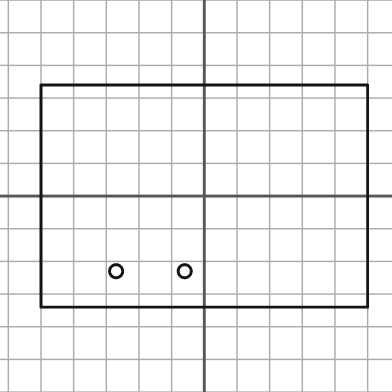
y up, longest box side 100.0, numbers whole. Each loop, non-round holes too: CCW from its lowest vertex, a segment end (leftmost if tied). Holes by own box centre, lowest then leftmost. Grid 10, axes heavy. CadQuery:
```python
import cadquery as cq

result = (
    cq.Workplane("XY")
    .moveTo(-50.0, -34.0)
    .lineTo(50.0, -34.0)
    .lineTo(50.0, 34.0)
    .lineTo(-50.0, 34.0)
    .close()
    .moveTo(-27.0, -23.0)
    .circle(2.0)
    .moveTo(-6.0, -23.0)
    .circle(2.0)
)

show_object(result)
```